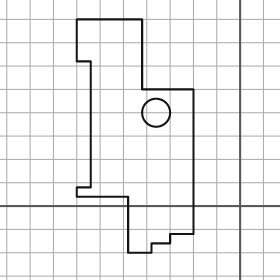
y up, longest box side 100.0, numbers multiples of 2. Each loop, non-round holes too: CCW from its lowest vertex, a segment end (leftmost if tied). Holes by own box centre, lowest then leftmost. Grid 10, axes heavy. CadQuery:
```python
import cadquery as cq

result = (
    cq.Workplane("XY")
    .moveTo(-48.0, -20.0)
    .lineTo(-38.0, -20.0)
    .lineTo(-38.0, -16.0)
    .lineTo(-30.0, -16.0)
    .lineTo(-30.0, -12.0)
    .lineTo(-20.0, -12.0)
    .lineTo(-20.0, 50.0)
    .lineTo(-42.0, 50.0)
    .lineTo(-42.0, 80.0)
    .lineTo(-70.0, 80.0)
    .lineTo(-70.0, 62.0)
    .lineTo(-64.0, 62.0)
    .lineTo(-64.0, 8.0)
    .lineTo(-70.0, 8.0)
    .lineTo(-70.0, 4.0)
    .lineTo(-48.0, 4.0)
    .close()
    .moveTo(-36.0, 40.0)
    .circle(6.0)
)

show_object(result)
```